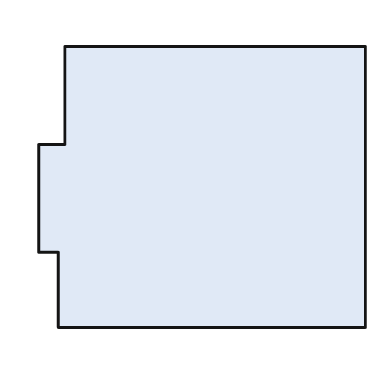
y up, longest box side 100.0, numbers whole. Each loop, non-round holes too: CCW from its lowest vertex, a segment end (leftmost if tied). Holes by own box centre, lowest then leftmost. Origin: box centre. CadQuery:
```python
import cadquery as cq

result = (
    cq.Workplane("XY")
    .moveTo(-44.0, -43.0)
    .lineTo(50.0, -43.0)
    .lineTo(50.0, 43.0)
    .lineTo(-42.0, 43.0)
    .lineTo(-42.0, 13.0)
    .lineTo(-50.0, 13.0)
    .lineTo(-50.0, -20.0)
    .lineTo(-44.0, -20.0)
    .close()
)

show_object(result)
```